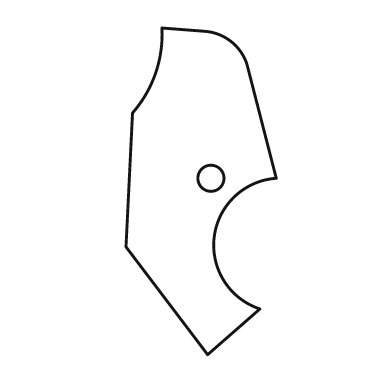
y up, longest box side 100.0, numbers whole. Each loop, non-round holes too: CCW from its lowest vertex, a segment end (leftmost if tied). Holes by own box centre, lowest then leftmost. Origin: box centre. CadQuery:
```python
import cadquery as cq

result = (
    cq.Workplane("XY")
    .moveTo(2.0, -50.0)
    .lineTo(18.0, -36.0)
    .threePointArc((4.0, -14.0), (23.0, 4.0))
    .lineTo(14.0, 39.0)
    .threePointArc((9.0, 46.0), (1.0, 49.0))
    .lineTo(-12.0, 50.0)
    .threePointArc((-14.0, 36.0), (-21.0, 24.0))
    .lineTo(-23.0, -17.0)
    .close()
    .moveTo(3.0, 4.0)
    .circle(4.0)
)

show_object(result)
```